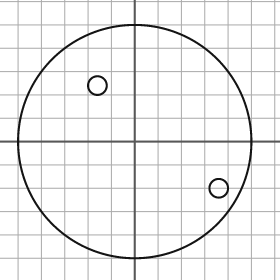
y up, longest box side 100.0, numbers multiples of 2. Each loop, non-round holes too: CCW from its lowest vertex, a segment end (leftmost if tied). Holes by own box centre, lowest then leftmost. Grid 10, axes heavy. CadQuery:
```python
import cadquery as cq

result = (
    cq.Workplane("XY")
    .moveTo(0.0, 0.0)
    .circle(50.0)
    .moveTo(36.0, -20.0)
    .circle(4.0)
    .moveTo(-16.0, 24.0)
    .circle(4.0)
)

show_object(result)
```